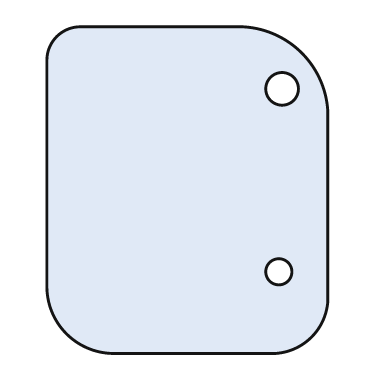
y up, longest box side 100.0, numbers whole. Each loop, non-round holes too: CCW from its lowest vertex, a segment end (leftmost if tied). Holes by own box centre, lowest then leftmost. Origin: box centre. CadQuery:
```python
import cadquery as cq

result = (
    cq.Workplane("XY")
    .moveTo(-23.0, -50.0)
    .lineTo(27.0, -50.0)
    .threePointArc((38.0, -45.0), (43.0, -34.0))
    .lineTo(43.0, 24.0)
    .threePointArc((35.0, 42.0), (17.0, 50.0))
    .lineTo(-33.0, 50.0)
    .threePointArc((-40.0, 47.0), (-43.0, 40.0))
    .lineTo(-43.0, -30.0)
    .threePointArc((-37.0, -44.0), (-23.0, -50.0))
    .close()
    .moveTo(28.0, -25.0)
    .circle(4.0)
    .moveTo(29.0, 31.0)
    .circle(5.0)
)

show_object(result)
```